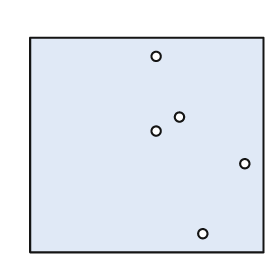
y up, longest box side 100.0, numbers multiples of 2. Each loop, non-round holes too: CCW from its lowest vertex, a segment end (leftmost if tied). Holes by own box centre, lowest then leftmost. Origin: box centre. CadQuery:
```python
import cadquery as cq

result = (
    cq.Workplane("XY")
    .moveTo(-50.0, -46.0)
    .lineTo(50.0, -46.0)
    .lineTo(50.0, 46.0)
    .lineTo(-50.0, 46.0)
    .close()
    .moveTo(24.0, -38.0)
    .circle(2.0)
    .moveTo(42.0, -8.0)
    .circle(2.0)
    .moveTo(4.0, 6.0)
    .circle(2.0)
    .moveTo(14.0, 12.0)
    .circle(2.0)
    .moveTo(4.0, 38.0)
    .circle(2.0)
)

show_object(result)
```